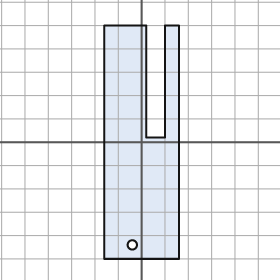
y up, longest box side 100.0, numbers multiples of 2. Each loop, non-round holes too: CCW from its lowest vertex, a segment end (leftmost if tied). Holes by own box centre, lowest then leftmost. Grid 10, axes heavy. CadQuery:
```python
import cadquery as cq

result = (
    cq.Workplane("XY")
    .moveTo(-16.0, -50.0)
    .lineTo(16.0, -50.0)
    .lineTo(16.0, 50.0)
    .lineTo(10.0, 50.0)
    .lineTo(10.0, 2.0)
    .lineTo(2.0, 2.0)
    .lineTo(2.0, 50.0)
    .lineTo(-16.0, 50.0)
    .close()
    .moveTo(-4.0, -44.0)
    .circle(2.0)
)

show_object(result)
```